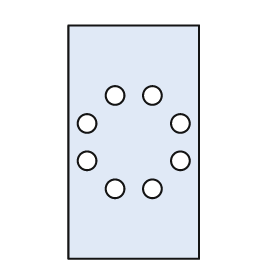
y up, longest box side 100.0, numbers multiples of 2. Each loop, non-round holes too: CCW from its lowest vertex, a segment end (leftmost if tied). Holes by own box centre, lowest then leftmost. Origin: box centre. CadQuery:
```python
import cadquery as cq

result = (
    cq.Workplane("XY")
    .moveTo(-28.0, -50.0)
    .lineTo(28.0, -50.0)
    .lineTo(28.0, 50.0)
    .lineTo(-28.0, 50.0)
    .close()
    .moveTo(-8.0, -20.0)
    .circle(4.0)
    .moveTo(8.0, -20.0)
    .circle(4.0)
    .moveTo(-20.0, -8.0)
    .circle(4.0)
    .moveTo(20.0, -8.0)
    .circle(4.0)
    .moveTo(-20.0, 8.0)
    .circle(4.0)
    .moveTo(20.0, 8.0)
    .circle(4.0)
    .moveTo(-8.0, 20.0)
    .circle(4.0)
    .moveTo(8.0, 20.0)
    .circle(4.0)
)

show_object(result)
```